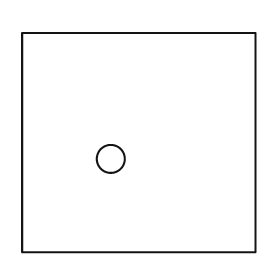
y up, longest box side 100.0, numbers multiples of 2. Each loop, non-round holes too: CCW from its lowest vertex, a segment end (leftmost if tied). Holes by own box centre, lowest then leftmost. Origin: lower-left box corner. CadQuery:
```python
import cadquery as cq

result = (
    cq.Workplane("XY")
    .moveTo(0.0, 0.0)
    .lineTo(100.0, 0.0)
    .lineTo(100.0, 94.0)
    .lineTo(0.0, 94.0)
    .close()
    .moveTo(38.0, 40.0)
    .circle(6.0)
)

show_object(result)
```